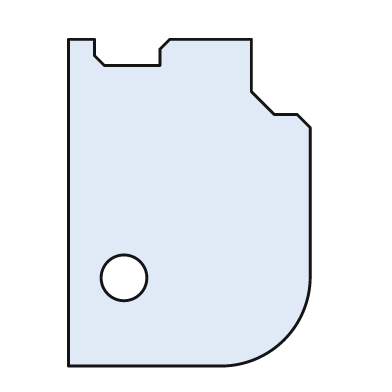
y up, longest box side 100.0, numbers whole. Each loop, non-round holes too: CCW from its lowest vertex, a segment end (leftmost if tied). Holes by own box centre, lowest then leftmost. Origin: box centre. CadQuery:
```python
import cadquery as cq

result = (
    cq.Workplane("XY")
    .moveTo(-37.0, -50.0)
    .lineTo(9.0, -50.0)
    .threePointArc((29.0, -42.0), (37.0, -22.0))
    .lineTo(37.0, 23.0)
    .lineTo(33.0, 27.0)
    .lineTo(26.0, 27.0)
    .lineTo(19.0, 34.0)
    .lineTo(19.0, 50.0)
    .lineTo(-6.0, 50.0)
    .lineTo(-9.0, 47.0)
    .lineTo(-9.0, 42.0)
    .lineTo(-26.0, 42.0)
    .lineTo(-29.0, 45.0)
    .lineTo(-29.0, 50.0)
    .lineTo(-37.0, 50.0)
    .close()
    .moveTo(-20.0, -23.0)
    .circle(7.0)
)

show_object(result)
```